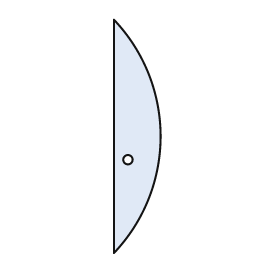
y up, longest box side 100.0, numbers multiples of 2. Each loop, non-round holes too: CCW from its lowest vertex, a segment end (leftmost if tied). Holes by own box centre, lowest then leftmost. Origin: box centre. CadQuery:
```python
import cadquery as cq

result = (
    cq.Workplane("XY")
    .moveTo(-10.0, -50.0)
    .threePointArc((10.0, 0.0), (-10.0, 50.0))
    .close()
    .moveTo(-4.0, -10.0)
    .circle(2.0)
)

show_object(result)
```